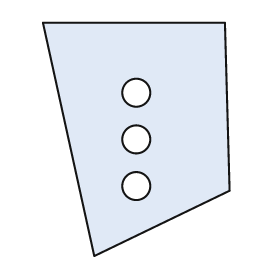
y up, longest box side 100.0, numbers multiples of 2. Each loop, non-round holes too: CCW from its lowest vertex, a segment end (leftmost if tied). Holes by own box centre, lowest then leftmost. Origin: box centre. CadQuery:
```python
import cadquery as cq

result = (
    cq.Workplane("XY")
    .moveTo(-18.0, -50.0)
    .lineTo(40.0, -22.0)
    .lineTo(38.0, 50.0)
    .lineTo(-40.0, 50.0)
    .close()
    .moveTo(0.0, -20.0)
    .circle(6.0)
    .moveTo(0.0, 0.0)
    .circle(6.0)
    .moveTo(0.0, 20.0)
    .circle(6.0)
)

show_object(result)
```